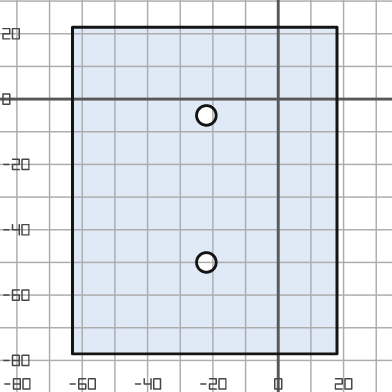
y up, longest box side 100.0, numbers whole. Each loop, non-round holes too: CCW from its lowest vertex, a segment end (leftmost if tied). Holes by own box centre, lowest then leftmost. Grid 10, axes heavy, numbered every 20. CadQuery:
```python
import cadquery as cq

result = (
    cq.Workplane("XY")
    .moveTo(-63.0, -78.0)
    .lineTo(18.0, -78.0)
    .lineTo(18.0, 22.0)
    .lineTo(-63.0, 22.0)
    .close()
    .moveTo(-22.0, -50.0)
    .circle(3.0)
    .moveTo(-22.0, -5.0)
    .circle(3.0)
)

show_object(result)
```